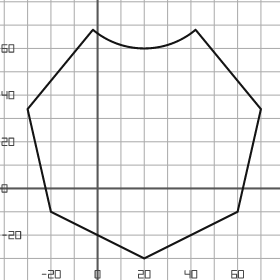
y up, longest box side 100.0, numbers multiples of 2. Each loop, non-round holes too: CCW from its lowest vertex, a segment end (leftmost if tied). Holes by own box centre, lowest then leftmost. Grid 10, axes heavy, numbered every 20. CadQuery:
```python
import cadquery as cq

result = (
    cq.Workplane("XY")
    .moveTo(20.0, -30.0)
    .lineTo(60.0, -10.0)
    .lineTo(70.0, 34.0)
    .lineTo(42.0, 68.0)
    .threePointArc((20.0, 60.0), (-2.0, 68.0))
    .lineTo(-30.0, 34.0)
    .lineTo(-20.0, -10.0)
    .close()
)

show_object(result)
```